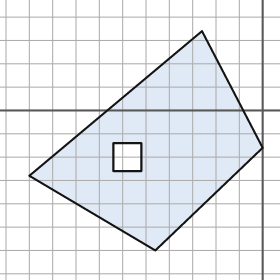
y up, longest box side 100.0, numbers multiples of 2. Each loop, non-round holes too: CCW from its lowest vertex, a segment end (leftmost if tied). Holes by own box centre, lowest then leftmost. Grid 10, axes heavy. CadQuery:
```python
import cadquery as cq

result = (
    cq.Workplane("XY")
    .moveTo(-46.0, -60.0)
    .lineTo(0.0, -16.0)
    .lineTo(-26.0, 34.0)
    .lineTo(-100.0, -28.0)
    .close()
    .moveTo(-64.0, -26.0)
    .lineTo(-52.0, -26.0)
    .lineTo(-52.0, -14.0)
    .lineTo(-64.0, -14.0)
    .close()
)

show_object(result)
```